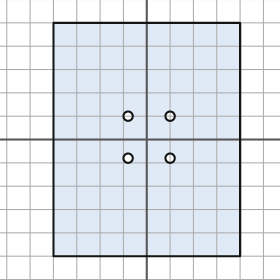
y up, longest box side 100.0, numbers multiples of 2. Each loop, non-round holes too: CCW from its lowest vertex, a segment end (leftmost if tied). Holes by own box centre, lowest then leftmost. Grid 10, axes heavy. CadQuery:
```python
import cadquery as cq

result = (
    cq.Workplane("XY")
    .moveTo(-40.0, -50.0)
    .lineTo(40.0, -50.0)
    .lineTo(40.0, 50.0)
    .lineTo(-40.0, 50.0)
    .close()
    .moveTo(-8.0, -8.0)
    .circle(2.0)
    .moveTo(10.0, -8.0)
    .circle(2.0)
    .moveTo(-8.0, 10.0)
    .circle(2.0)
    .moveTo(10.0, 10.0)
    .circle(2.0)
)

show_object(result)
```